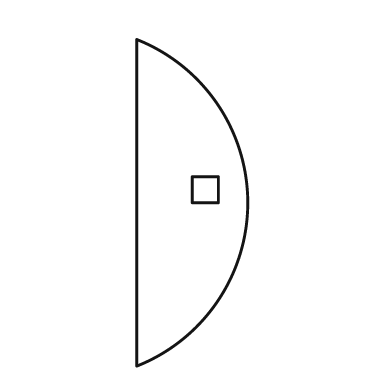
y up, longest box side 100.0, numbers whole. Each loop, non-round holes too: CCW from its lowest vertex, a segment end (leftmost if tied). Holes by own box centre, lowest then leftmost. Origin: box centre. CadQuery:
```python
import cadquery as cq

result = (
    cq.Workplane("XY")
    .moveTo(-17.0, -50.0)
    .threePointArc((17.0, 0.0), (-17.0, 50.0))
    .close()
    .moveTo(0.0, 0.0)
    .lineTo(8.0, 0.0)
    .lineTo(8.0, 8.0)
    .lineTo(0.0, 8.0)
    .close()
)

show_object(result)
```